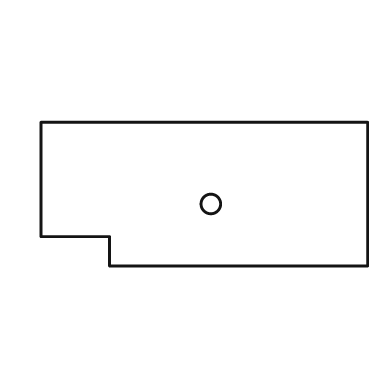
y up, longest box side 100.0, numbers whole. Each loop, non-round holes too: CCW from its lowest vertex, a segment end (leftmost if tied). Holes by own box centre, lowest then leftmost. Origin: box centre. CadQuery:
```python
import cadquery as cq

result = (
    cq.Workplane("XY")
    .moveTo(-29.0, -22.0)
    .lineTo(50.0, -22.0)
    .lineTo(50.0, 22.0)
    .lineTo(-50.0, 22.0)
    .lineTo(-50.0, -13.0)
    .lineTo(-29.0, -13.0)
    .close()
    .moveTo(2.0, -3.0)
    .circle(3.0)
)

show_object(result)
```